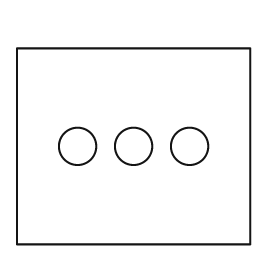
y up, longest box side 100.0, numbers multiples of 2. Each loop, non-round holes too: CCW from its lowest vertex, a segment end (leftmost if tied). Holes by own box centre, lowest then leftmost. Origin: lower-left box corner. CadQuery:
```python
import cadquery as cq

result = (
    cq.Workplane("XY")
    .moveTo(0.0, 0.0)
    .lineTo(100.0, 0.0)
    .lineTo(100.0, 84.0)
    .lineTo(0.0, 84.0)
    .close()
    .moveTo(26.0, 42.0)
    .circle(8.0)
    .moveTo(50.0, 42.0)
    .circle(8.0)
    .moveTo(74.0, 42.0)
    .circle(8.0)
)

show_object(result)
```